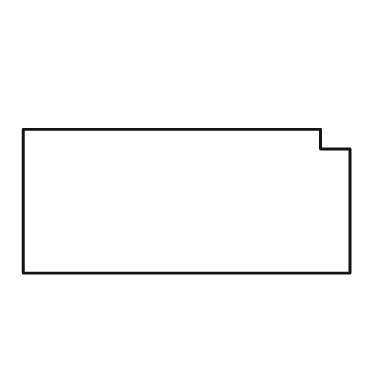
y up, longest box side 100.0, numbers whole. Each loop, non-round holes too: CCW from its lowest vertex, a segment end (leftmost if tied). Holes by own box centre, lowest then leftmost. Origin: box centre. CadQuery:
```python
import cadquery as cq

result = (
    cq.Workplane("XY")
    .moveTo(-50.0, -22.0)
    .lineTo(50.0, -22.0)
    .lineTo(50.0, 16.0)
    .lineTo(41.0, 16.0)
    .lineTo(41.0, 22.0)
    .lineTo(-50.0, 22.0)
    .close()
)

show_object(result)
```